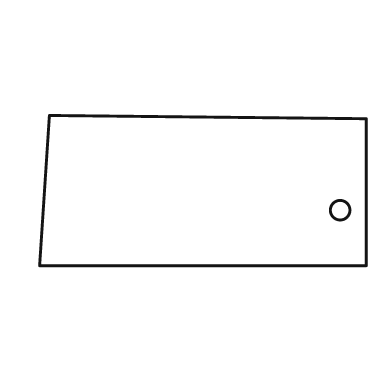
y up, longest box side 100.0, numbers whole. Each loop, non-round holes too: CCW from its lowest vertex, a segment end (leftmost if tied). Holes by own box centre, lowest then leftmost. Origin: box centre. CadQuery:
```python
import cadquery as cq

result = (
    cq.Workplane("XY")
    .moveTo(-50.0, -23.0)
    .lineTo(50.0, -23.0)
    .lineTo(50.0, 22.0)
    .lineTo(-47.0, 23.0)
    .close()
    .moveTo(42.0, -6.0)
    .circle(3.0)
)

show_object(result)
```